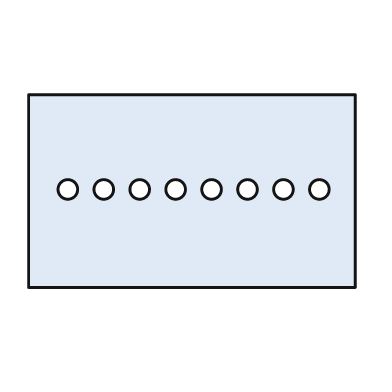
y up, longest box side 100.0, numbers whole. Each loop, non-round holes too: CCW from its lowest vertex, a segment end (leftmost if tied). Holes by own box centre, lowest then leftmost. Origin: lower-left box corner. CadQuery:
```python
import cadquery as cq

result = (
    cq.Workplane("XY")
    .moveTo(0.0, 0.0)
    .lineTo(100.0, 0.0)
    .lineTo(100.0, 59.0)
    .lineTo(0.0, 59.0)
    .close()
    .moveTo(12.0, 30.0)
    .circle(3.0)
    .moveTo(23.0, 30.0)
    .circle(3.0)
    .moveTo(34.0, 30.0)
    .circle(3.0)
    .moveTo(45.0, 30.0)
    .circle(3.0)
    .moveTo(56.0, 30.0)
    .circle(3.0)
    .moveTo(67.0, 30.0)
    .circle(3.0)
    .moveTo(78.0, 30.0)
    .circle(3.0)
    .moveTo(89.0, 30.0)
    .circle(3.0)
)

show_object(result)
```